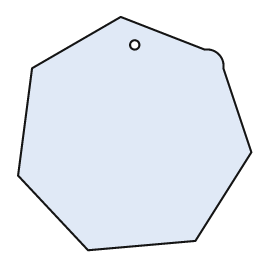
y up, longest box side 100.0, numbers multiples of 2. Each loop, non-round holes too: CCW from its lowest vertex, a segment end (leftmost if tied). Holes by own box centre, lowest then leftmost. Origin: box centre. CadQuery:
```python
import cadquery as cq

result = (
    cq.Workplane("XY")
    .moveTo(-20.0, -50.0)
    .lineTo(26.0, -46.0)
    .lineTo(50.0, -8.0)
    .lineTo(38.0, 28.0)
    .threePointArc((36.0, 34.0), (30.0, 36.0))
    .lineTo(-6.0, 50.0)
    .lineTo(-44.0, 28.0)
    .lineTo(-50.0, -18.0)
    .close()
    .moveTo(0.0, 38.0)
    .circle(2.0)
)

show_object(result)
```